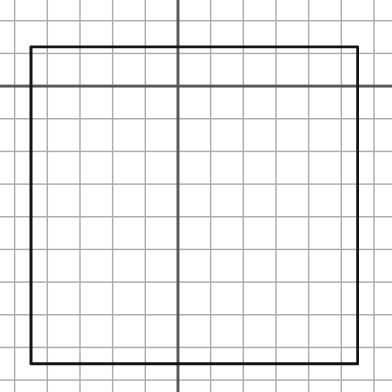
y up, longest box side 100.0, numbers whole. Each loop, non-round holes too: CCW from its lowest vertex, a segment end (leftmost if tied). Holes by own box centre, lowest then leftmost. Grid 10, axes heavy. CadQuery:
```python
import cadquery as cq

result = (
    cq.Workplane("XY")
    .moveTo(-45.0, -85.0)
    .lineTo(55.0, -85.0)
    .lineTo(55.0, 12.0)
    .lineTo(-45.0, 12.0)
    .close()
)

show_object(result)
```